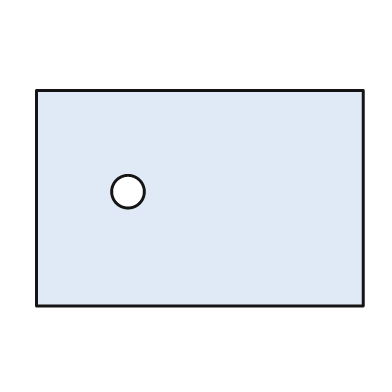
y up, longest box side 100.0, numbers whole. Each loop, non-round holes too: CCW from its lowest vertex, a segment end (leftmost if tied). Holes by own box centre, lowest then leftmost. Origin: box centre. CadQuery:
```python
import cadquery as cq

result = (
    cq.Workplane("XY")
    .moveTo(-50.0, -33.0)
    .lineTo(50.0, -33.0)
    .lineTo(50.0, 33.0)
    .lineTo(-50.0, 33.0)
    .close()
    .moveTo(-22.0, 2.0)
    .circle(5.0)
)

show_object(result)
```